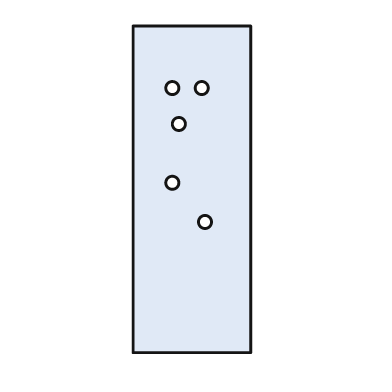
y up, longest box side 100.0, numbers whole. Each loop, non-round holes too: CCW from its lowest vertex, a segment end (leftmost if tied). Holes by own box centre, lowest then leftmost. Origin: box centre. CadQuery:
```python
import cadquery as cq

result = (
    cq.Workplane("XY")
    .moveTo(-18.0, -50.0)
    .lineTo(18.0, -50.0)
    .lineTo(18.0, 50.0)
    .lineTo(-18.0, 50.0)
    .close()
    .moveTo(4.0, -10.0)
    .circle(2.0)
    .moveTo(-6.0, 2.0)
    .circle(2.0)
    .moveTo(-4.0, 20.0)
    .circle(2.0)
    .moveTo(-6.0, 31.0)
    .circle(2.0)
    .moveTo(3.0, 31.0)
    .circle(2.0)
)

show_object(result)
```